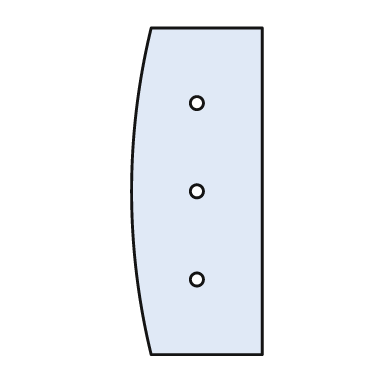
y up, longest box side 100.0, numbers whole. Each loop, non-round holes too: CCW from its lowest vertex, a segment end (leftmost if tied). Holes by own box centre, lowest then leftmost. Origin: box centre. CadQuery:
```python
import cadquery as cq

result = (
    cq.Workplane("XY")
    .moveTo(-14.0, -50.0)
    .lineTo(20.0, -50.0)
    .lineTo(20.0, 50.0)
    .lineTo(-14.0, 50.0)
    .threePointArc((-20.0, 0.0), (-14.0, -50.0))
    .close()
    .moveTo(0.0, -27.0)
    .circle(2.0)
    .moveTo(0.0, 0.0)
    .circle(2.0)
    .moveTo(0.0, 27.0)
    .circle(2.0)
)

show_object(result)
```